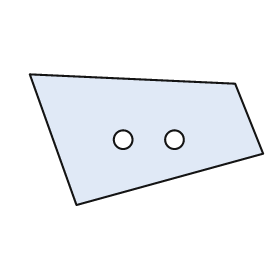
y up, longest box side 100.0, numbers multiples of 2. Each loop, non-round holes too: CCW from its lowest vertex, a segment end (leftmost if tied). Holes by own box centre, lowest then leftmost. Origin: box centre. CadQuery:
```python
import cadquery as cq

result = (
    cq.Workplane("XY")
    .moveTo(-30.0, -28.0)
    .lineTo(50.0, -6.0)
    .lineTo(38.0, 24.0)
    .lineTo(-50.0, 28.0)
    .close()
    .moveTo(-10.0, 0.0)
    .circle(4.0)
    .moveTo(12.0, 0.0)
    .circle(4.0)
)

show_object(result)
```